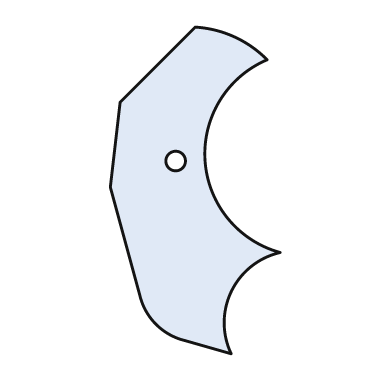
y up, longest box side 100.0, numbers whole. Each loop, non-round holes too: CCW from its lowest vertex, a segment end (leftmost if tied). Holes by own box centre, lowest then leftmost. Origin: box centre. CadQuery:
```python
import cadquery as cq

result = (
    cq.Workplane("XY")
    .moveTo(11.0, -50.0)
    .threePointArc((11.0, -31.0), (26.0, -19.0))
    .threePointArc((3.0, 9.0), (22.0, 40.0))
    .threePointArc((12.0, 47.0), (0.0, 50.0))
    .lineTo(-23.0, 27.0)
    .lineTo(-26.0, 1.0)
    .lineTo(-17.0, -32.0)
    .threePointArc((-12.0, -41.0), (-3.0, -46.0))
    .close()
    .moveTo(-6.0, 9.0)
    .circle(3.0)
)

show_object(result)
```